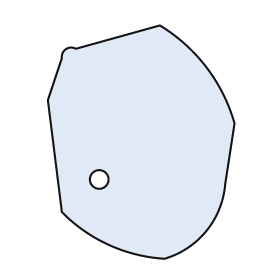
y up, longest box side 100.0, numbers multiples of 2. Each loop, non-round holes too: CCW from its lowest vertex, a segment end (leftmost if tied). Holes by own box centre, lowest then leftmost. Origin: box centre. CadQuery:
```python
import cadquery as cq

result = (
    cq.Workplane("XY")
    .moveTo(10.0, -50.0)
    .threePointArc((28.0, -38.0), (36.0, -18.0))
    .lineTo(40.0, 8.0)
    .threePointArc((28.0, 32.0), (8.0, 50.0))
    .lineTo(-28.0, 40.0)
    .threePointArc((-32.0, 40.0), (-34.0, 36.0))
    .lineTo(-40.0, 18.0)
    .lineTo(-34.0, -30.0)
    .threePointArc((-14.0, -44.0), (10.0, -50.0))
    .close()
    .moveTo(-18.0, -16.0)
    .circle(4.0)
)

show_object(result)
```